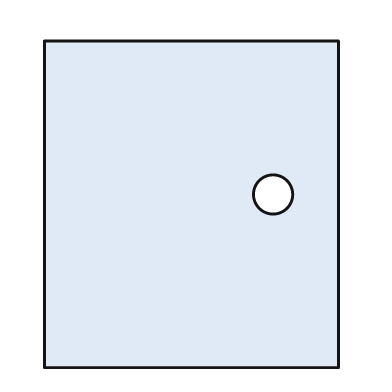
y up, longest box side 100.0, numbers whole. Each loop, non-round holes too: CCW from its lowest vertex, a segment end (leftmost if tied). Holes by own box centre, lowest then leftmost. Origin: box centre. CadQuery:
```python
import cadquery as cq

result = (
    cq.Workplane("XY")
    .moveTo(-45.0, -50.0)
    .lineTo(45.0, -50.0)
    .lineTo(45.0, 50.0)
    .lineTo(-45.0, 50.0)
    .close()
    .moveTo(25.0, 3.0)
    .circle(6.0)
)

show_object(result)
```